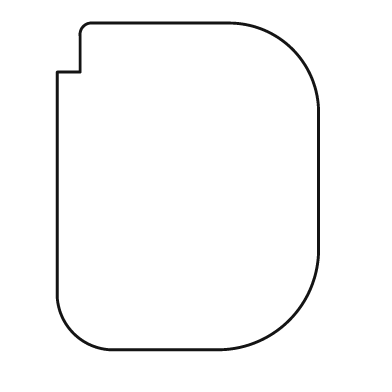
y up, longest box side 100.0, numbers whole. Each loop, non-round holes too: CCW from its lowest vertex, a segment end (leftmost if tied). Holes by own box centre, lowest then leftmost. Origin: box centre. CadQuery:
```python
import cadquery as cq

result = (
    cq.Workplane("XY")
    .moveTo(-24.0, -50.0)
    .lineTo(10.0, -50.0)
    .threePointArc((31.0, -41.0), (40.0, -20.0))
    .lineTo(40.0, 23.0)
    .threePointArc((32.0, 42.0), (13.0, 50.0))
    .lineTo(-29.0, 50.0)
    .threePointArc((-32.0, 49.0), (-33.0, 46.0))
    .lineTo(-33.0, 35.0)
    .lineTo(-40.0, 35.0)
    .lineTo(-40.0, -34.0)
    .threePointArc((-35.0, -45.0), (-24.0, -50.0))
    .close()
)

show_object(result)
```